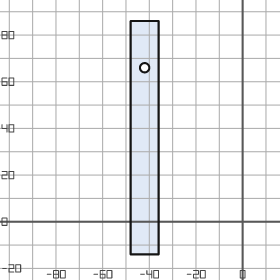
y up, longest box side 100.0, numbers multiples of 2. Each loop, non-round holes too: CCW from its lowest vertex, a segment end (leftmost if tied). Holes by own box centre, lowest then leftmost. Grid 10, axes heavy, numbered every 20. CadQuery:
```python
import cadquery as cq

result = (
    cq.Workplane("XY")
    .moveTo(-48.0, -14.0)
    .lineTo(-36.0, -14.0)
    .lineTo(-36.0, 86.0)
    .lineTo(-48.0, 86.0)
    .close()
    .moveTo(-42.0, 66.0)
    .circle(2.0)
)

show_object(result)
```